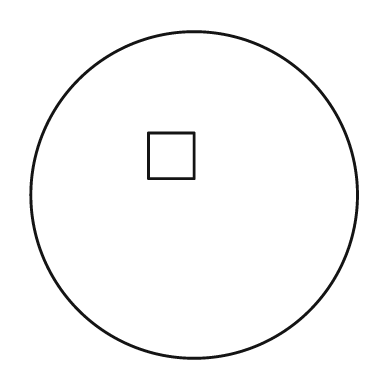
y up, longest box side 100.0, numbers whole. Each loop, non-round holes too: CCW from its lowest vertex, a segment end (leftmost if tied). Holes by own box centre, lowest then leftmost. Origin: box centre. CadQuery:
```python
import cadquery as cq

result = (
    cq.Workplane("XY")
    .moveTo(0.0, 0.0)
    .circle(50.0)
    .moveTo(-14.0, 5.0)
    .lineTo(0.0, 5.0)
    .lineTo(0.0, 19.0)
    .lineTo(-14.0, 19.0)
    .close()
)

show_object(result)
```